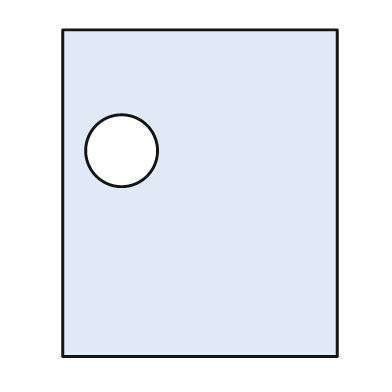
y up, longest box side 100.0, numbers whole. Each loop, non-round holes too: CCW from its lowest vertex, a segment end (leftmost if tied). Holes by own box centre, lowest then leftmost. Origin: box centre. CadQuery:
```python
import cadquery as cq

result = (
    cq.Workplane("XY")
    .moveTo(-42.0, -50.0)
    .lineTo(42.0, -50.0)
    .lineTo(42.0, 50.0)
    .lineTo(-42.0, 50.0)
    .close()
    .moveTo(-24.0, 13.0)
    .circle(11.0)
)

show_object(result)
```